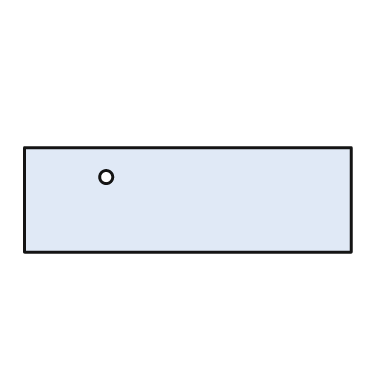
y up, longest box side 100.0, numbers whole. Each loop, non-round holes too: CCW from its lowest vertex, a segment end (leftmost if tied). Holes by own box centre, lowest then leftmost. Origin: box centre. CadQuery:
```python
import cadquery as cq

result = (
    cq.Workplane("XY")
    .moveTo(-50.0, -16.0)
    .lineTo(50.0, -16.0)
    .lineTo(50.0, 16.0)
    .lineTo(-50.0, 16.0)
    .close()
    .moveTo(-25.0, 7.0)
    .circle(2.0)
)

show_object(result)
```